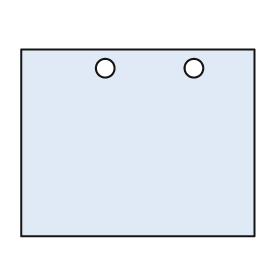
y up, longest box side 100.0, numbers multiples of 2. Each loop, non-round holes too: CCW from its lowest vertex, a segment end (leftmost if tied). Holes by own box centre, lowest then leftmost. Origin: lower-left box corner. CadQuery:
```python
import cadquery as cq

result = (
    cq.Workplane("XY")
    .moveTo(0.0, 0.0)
    .lineTo(100.0, 0.0)
    .lineTo(100.0, 80.0)
    .lineTo(0.0, 80.0)
    .close()
    .moveTo(36.0, 72.0)
    .circle(4.0)
    .moveTo(74.0, 72.0)
    .circle(4.0)
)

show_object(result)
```